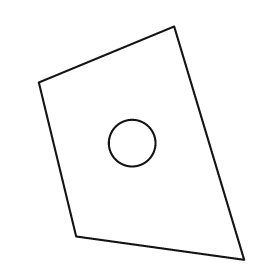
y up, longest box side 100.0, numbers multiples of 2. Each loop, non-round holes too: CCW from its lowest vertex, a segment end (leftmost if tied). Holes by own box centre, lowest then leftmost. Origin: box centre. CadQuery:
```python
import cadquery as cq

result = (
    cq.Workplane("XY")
    .moveTo(44.0, -50.0)
    .lineTo(14.0, 50.0)
    .lineTo(-44.0, 26.0)
    .lineTo(-28.0, -40.0)
    .close()
    .moveTo(-4.0, 0.0)
    .circle(10.0)
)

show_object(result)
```